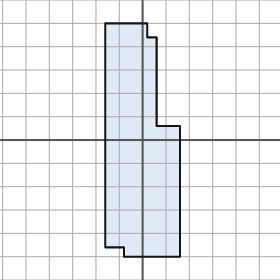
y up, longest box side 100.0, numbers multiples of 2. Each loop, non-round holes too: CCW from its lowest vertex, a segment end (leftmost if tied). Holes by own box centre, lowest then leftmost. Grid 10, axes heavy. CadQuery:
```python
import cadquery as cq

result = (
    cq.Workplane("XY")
    .moveTo(-8.0, -50.0)
    .lineTo(16.0, -50.0)
    .lineTo(16.0, 6.0)
    .lineTo(6.0, 6.0)
    .lineTo(6.0, 44.0)
    .lineTo(2.0, 44.0)
    .lineTo(2.0, 50.0)
    .lineTo(-16.0, 50.0)
    .lineTo(-16.0, -46.0)
    .lineTo(-8.0, -46.0)
    .close()
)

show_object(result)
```